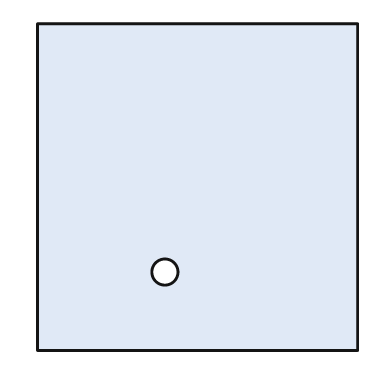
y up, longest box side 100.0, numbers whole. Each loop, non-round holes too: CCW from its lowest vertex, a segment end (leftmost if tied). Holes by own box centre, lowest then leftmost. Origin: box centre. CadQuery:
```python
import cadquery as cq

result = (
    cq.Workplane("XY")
    .moveTo(-49.0, -50.0)
    .lineTo(49.0, -50.0)
    .lineTo(49.0, 50.0)
    .lineTo(-49.0, 50.0)
    .close()
    .moveTo(-10.0, -26.0)
    .circle(4.0)
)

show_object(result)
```